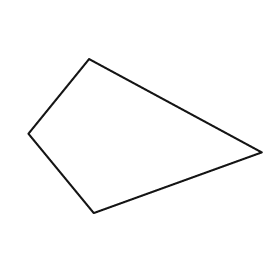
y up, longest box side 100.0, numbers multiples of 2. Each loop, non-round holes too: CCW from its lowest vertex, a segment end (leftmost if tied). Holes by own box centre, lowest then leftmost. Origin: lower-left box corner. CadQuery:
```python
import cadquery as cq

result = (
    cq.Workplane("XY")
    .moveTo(28.0, 0.0)
    .lineTo(100.0, 26.0)
    .lineTo(26.0, 66.0)
    .lineTo(0.0, 34.0)
    .close()
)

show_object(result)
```